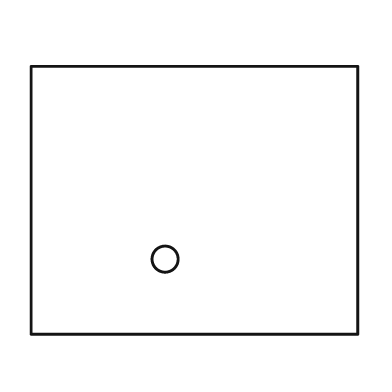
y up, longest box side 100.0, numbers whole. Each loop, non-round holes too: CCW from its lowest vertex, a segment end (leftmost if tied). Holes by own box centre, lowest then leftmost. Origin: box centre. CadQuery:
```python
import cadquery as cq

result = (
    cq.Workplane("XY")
    .moveTo(-50.0, -41.0)
    .lineTo(50.0, -41.0)
    .lineTo(50.0, 41.0)
    .lineTo(-50.0, 41.0)
    .close()
    .moveTo(-9.0, -18.0)
    .circle(4.0)
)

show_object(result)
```